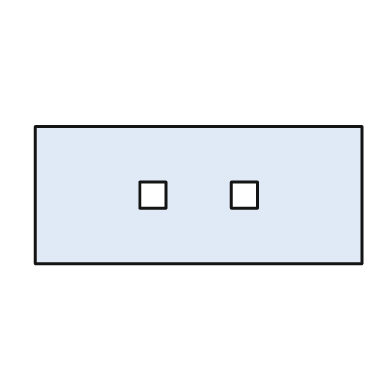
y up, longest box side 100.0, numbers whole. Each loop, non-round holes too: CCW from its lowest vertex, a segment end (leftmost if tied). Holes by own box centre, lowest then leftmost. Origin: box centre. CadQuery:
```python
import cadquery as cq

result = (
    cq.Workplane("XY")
    .moveTo(-50.0, -21.0)
    .lineTo(50.0, -21.0)
    .lineTo(50.0, 21.0)
    .lineTo(-50.0, 21.0)
    .close()
    .moveTo(-18.0, -4.0)
    .lineTo(-10.0, -4.0)
    .lineTo(-10.0, 4.0)
    .lineTo(-18.0, 4.0)
    .close()
    .moveTo(10.0, -4.0)
    .lineTo(18.0, -4.0)
    .lineTo(18.0, 4.0)
    .lineTo(10.0, 4.0)
    .close()
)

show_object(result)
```